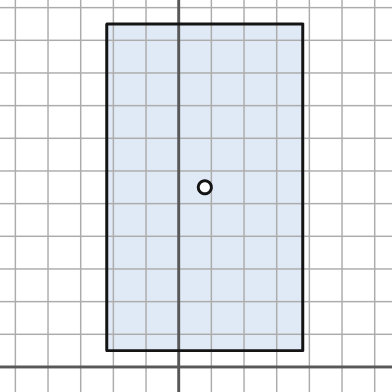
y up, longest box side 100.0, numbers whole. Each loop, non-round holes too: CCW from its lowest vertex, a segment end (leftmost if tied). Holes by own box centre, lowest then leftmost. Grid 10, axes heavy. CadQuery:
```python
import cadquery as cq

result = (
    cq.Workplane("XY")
    .moveTo(-22.0, 5.0)
    .lineTo(38.0, 5.0)
    .lineTo(38.0, 105.0)
    .lineTo(-22.0, 105.0)
    .close()
    .moveTo(8.0, 55.0)
    .circle(2.0)
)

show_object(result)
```